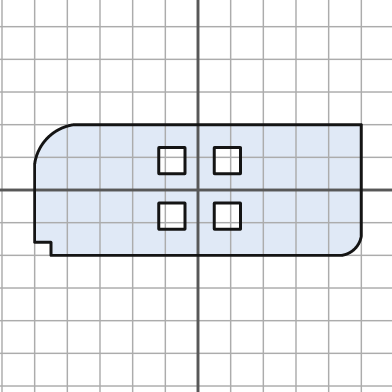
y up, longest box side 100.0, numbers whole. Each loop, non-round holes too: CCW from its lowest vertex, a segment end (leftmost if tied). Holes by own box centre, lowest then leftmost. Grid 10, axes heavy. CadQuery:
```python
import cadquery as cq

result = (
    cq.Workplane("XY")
    .moveTo(-45.0, -20.0)
    .lineTo(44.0, -20.0)
    .threePointArc((48.0, -18.0), (50.0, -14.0))
    .lineTo(50.0, 20.0)
    .lineTo(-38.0, 20.0)
    .threePointArc((-46.0, 16.0), (-50.0, 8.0))
    .lineTo(-50.0, -16.0)
    .lineTo(-45.0, -16.0)
    .close()
    .moveTo(-12.0, -12.0)
    .lineTo(-4.0, -12.0)
    .lineTo(-4.0, -4.0)
    .lineTo(-12.0, -4.0)
    .close()
    .moveTo(5.0, -12.0)
    .lineTo(13.0, -12.0)
    .lineTo(13.0, -4.0)
    .lineTo(5.0, -4.0)
    .close()
    .moveTo(-12.0, 5.0)
    .lineTo(-4.0, 5.0)
    .lineTo(-4.0, 13.0)
    .lineTo(-12.0, 13.0)
    .close()
    .moveTo(5.0, 5.0)
    .lineTo(13.0, 5.0)
    .lineTo(13.0, 13.0)
    .lineTo(5.0, 13.0)
    .close()
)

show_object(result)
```